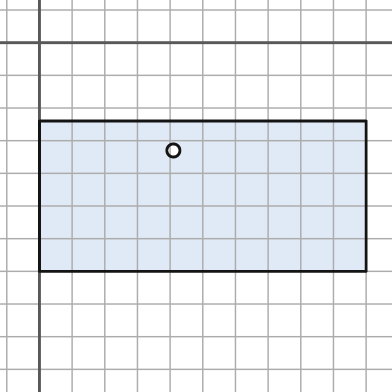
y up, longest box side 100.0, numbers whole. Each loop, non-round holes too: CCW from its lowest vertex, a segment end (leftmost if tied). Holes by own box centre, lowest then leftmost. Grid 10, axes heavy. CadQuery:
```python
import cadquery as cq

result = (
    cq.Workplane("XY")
    .moveTo(0.0, -70.0)
    .lineTo(100.0, -70.0)
    .lineTo(100.0, -24.0)
    .lineTo(0.0, -24.0)
    .close()
    .moveTo(41.0, -33.0)
    .circle(2.0)
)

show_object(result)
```